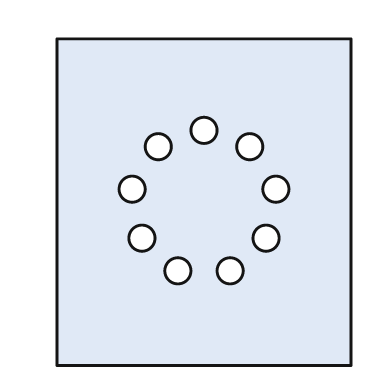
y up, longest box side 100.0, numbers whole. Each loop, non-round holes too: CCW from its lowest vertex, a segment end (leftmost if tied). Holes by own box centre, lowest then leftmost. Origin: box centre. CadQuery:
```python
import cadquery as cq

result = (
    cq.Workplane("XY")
    .moveTo(-45.0, -50.0)
    .lineTo(45.0, -50.0)
    .lineTo(45.0, 50.0)
    .lineTo(-45.0, 50.0)
    .close()
    .moveTo(-8.0, -21.0)
    .circle(4.0)
    .moveTo(8.0, -21.0)
    .circle(4.0)
    .moveTo(-19.0, -11.0)
    .circle(4.0)
    .moveTo(19.0, -11.0)
    .circle(4.0)
    .moveTo(-22.0, 4.0)
    .circle(4.0)
    .moveTo(22.0, 4.0)
    .circle(4.0)
    .moveTo(-14.0, 17.0)
    .circle(4.0)
    .moveTo(14.0, 17.0)
    .circle(4.0)
    .moveTo(0.0, 22.0)
    .circle(4.0)
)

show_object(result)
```